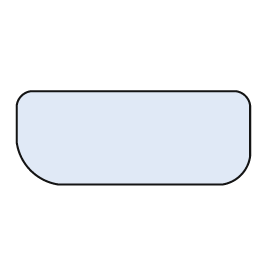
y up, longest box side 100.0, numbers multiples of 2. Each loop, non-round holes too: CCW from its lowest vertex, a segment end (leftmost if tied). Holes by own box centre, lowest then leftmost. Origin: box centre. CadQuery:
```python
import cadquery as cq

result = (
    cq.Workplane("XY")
    .moveTo(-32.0, -20.0)
    .lineTo(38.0, -20.0)
    .threePointArc((46.0, -16.0), (50.0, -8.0))
    .lineTo(50.0, 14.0)
    .threePointArc((48.0, 18.0), (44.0, 20.0))
    .lineTo(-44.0, 20.0)
    .threePointArc((-48.0, 18.0), (-50.0, 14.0))
    .lineTo(-50.0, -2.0)
    .threePointArc((-44.0, -14.0), (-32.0, -20.0))
    .close()
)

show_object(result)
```